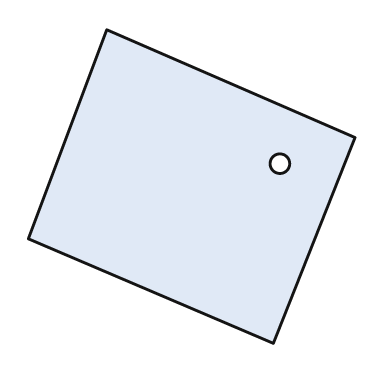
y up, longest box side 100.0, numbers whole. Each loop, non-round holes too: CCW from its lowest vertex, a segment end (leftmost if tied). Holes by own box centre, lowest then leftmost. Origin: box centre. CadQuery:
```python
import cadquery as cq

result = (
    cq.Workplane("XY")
    .moveTo(25.0, -48.0)
    .lineTo(50.0, 15.0)
    .lineTo(-26.0, 48.0)
    .lineTo(-50.0, -16.0)
    .close()
    .moveTo(27.0, 7.0)
    .circle(3.0)
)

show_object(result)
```